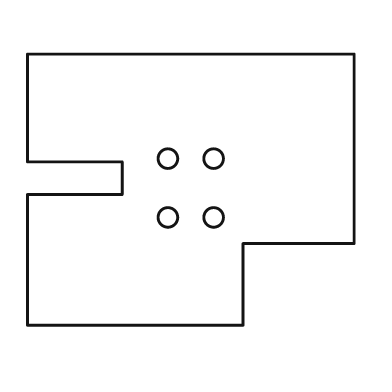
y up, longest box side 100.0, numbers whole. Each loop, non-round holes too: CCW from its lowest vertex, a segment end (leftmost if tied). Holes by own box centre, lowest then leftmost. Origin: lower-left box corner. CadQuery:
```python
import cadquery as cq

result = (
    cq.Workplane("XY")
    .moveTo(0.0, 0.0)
    .lineTo(66.0, 0.0)
    .lineTo(66.0, 25.0)
    .lineTo(100.0, 25.0)
    .lineTo(100.0, 83.0)
    .lineTo(0.0, 83.0)
    .lineTo(0.0, 50.0)
    .lineTo(29.0, 50.0)
    .lineTo(29.0, 40.0)
    .lineTo(0.0, 40.0)
    .close()
    .moveTo(43.0, 33.0)
    .circle(3.0)
    .moveTo(57.0, 33.0)
    .circle(3.0)
    .moveTo(43.0, 51.0)
    .circle(3.0)
    .moveTo(57.0, 51.0)
    .circle(3.0)
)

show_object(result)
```